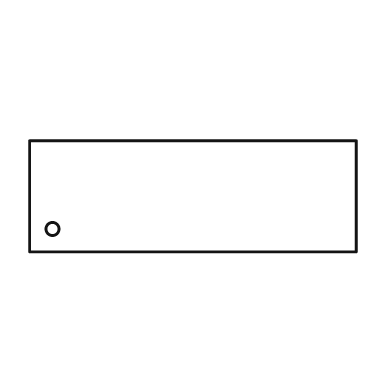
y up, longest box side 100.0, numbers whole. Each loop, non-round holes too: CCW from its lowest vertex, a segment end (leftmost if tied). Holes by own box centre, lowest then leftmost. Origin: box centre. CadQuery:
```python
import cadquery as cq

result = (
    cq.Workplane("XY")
    .moveTo(-50.0, -17.0)
    .lineTo(50.0, -17.0)
    .lineTo(50.0, 17.0)
    .lineTo(-50.0, 17.0)
    .close()
    .moveTo(-43.0, -10.0)
    .circle(2.0)
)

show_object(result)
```